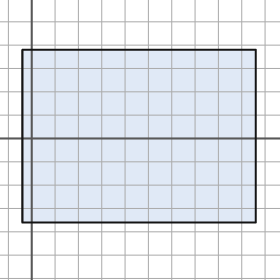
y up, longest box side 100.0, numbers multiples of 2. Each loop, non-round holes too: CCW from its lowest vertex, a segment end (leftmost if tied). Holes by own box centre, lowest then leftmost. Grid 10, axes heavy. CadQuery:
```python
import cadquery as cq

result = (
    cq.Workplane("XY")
    .moveTo(-4.0, -36.0)
    .lineTo(96.0, -36.0)
    .lineTo(96.0, 38.0)
    .lineTo(-4.0, 38.0)
    .close()
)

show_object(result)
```